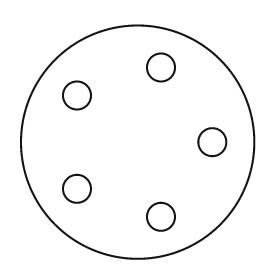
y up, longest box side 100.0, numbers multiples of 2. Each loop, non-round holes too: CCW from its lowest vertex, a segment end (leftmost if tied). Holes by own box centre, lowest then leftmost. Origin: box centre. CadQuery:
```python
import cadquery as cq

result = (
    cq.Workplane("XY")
    .moveTo(0.0, 0.0)
    .circle(50.0)
    .moveTo(10.0, -32.0)
    .circle(6.0)
    .moveTo(-26.0, -20.0)
    .circle(6.0)
    .moveTo(32.0, 0.0)
    .circle(6.0)
    .moveTo(-26.0, 20.0)
    .circle(6.0)
    .moveTo(10.0, 32.0)
    .circle(6.0)
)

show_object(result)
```